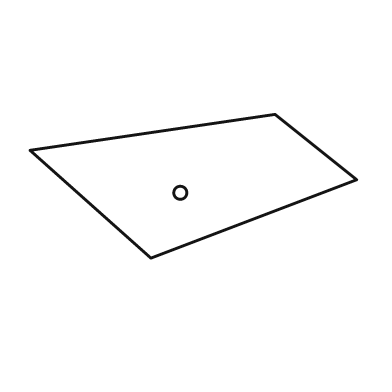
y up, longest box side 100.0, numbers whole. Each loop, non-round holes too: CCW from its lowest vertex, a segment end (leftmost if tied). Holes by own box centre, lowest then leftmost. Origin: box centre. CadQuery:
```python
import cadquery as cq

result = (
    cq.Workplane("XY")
    .moveTo(-13.0, -22.0)
    .lineTo(50.0, 2.0)
    .lineTo(25.0, 22.0)
    .lineTo(-50.0, 11.0)
    .close()
    .moveTo(-4.0, -2.0)
    .circle(2.0)
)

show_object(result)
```